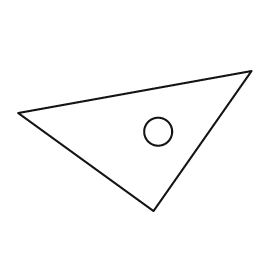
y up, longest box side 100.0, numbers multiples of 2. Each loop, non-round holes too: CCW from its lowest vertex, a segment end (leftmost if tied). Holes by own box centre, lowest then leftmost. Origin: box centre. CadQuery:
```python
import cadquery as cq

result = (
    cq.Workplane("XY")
    .moveTo(8.0, -30.0)
    .lineTo(50.0, 30.0)
    .lineTo(-50.0, 12.0)
    .close()
    .moveTo(10.0, 4.0)
    .circle(6.0)
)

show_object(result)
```